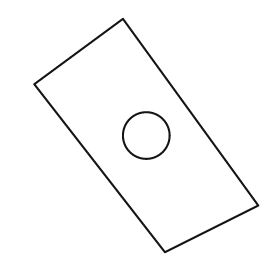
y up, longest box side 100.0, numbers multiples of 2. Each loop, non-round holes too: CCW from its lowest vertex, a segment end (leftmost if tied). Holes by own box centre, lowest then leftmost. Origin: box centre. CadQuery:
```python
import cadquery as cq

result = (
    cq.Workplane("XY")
    .moveTo(8.0, -50.0)
    .lineTo(48.0, -30.0)
    .lineTo(-10.0, 50.0)
    .lineTo(-48.0, 22.0)
    .close()
    .moveTo(0.0, 0.0)
    .circle(10.0)
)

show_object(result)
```